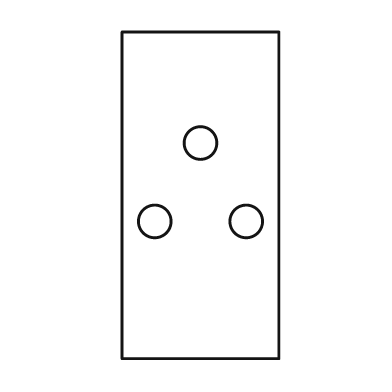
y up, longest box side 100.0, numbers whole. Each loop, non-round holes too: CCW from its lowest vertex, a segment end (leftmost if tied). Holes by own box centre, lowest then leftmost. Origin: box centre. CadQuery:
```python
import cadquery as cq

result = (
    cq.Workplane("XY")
    .moveTo(-24.0, -50.0)
    .lineTo(24.0, -50.0)
    .lineTo(24.0, 50.0)
    .lineTo(-24.0, 50.0)
    .close()
    .moveTo(-14.0, -8.0)
    .circle(5.0)
    .moveTo(14.0, -8.0)
    .circle(5.0)
    .moveTo(0.0, 16.0)
    .circle(5.0)
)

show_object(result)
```